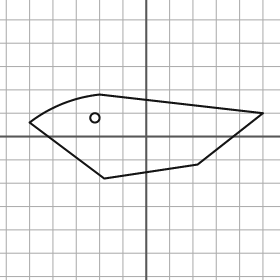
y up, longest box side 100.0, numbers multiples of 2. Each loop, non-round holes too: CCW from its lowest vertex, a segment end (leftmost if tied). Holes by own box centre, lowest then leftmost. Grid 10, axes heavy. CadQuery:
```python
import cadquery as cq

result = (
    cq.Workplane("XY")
    .moveTo(-18.0, -18.0)
    .lineTo(22.0, -12.0)
    .lineTo(50.0, 10.0)
    .lineTo(-20.0, 18.0)
    .threePointArc((-36.0, 14.0), (-50.0, 6.0))
    .close()
    .moveTo(-22.0, 8.0)
    .circle(2.0)
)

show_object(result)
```